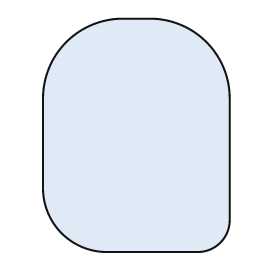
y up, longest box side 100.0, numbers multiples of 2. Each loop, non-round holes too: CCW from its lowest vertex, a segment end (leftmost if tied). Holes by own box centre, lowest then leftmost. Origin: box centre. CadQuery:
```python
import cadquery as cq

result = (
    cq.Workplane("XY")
    .moveTo(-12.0, -50.0)
    .lineTo(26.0, -50.0)
    .threePointArc((36.0, -46.0), (40.0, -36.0))
    .lineTo(40.0, 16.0)
    .threePointArc((30.0, 40.0), (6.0, 50.0))
    .lineTo(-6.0, 50.0)
    .threePointArc((-30.0, 40.0), (-40.0, 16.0))
    .lineTo(-40.0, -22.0)
    .threePointArc((-32.0, -42.0), (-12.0, -50.0))
    .close()
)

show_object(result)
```